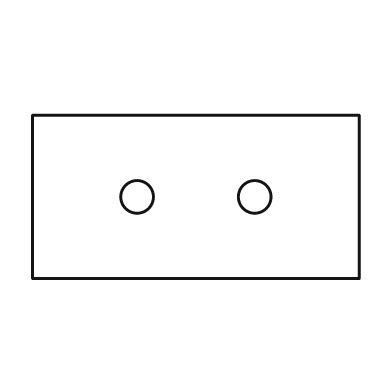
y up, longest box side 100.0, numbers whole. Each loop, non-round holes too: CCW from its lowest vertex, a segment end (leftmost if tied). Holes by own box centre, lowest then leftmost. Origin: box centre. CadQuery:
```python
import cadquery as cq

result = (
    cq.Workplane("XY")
    .moveTo(-50.0, -25.0)
    .lineTo(50.0, -25.0)
    .lineTo(50.0, 25.0)
    .lineTo(-50.0, 25.0)
    .close()
    .moveTo(-18.0, 0.0)
    .circle(5.0)
    .moveTo(18.0, 0.0)
    .circle(5.0)
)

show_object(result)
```